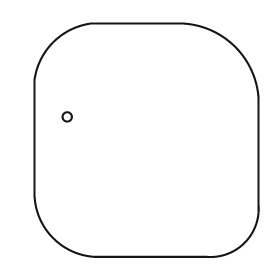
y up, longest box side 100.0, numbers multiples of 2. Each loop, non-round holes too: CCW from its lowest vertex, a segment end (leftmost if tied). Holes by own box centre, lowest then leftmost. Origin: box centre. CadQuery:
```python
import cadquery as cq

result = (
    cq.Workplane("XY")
    .moveTo(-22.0, -50.0)
    .lineTo(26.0, -50.0)
    .threePointArc((42.0, -44.0), (48.0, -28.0))
    .lineTo(48.0, 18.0)
    .threePointArc((38.0, 40.0), (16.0, 50.0))
    .lineTo(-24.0, 50.0)
    .threePointArc((-40.0, 42.0), (-48.0, 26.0))
    .lineTo(-48.0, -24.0)
    .threePointArc((-40.0, -42.0), (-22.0, -50.0))
    .close()
    .moveTo(-34.0, 10.0)
    .circle(2.0)
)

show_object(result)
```